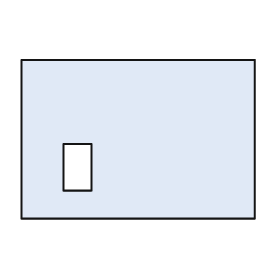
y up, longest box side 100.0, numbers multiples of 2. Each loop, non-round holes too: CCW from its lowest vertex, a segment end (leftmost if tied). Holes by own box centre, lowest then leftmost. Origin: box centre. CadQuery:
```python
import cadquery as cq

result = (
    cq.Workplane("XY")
    .moveTo(-50.0, -34.0)
    .lineTo(50.0, -34.0)
    .lineTo(50.0, 34.0)
    .lineTo(-50.0, 34.0)
    .close()
    .moveTo(-32.0, -22.0)
    .lineTo(-20.0, -22.0)
    .lineTo(-20.0, -2.0)
    .lineTo(-32.0, -2.0)
    .close()
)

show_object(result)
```